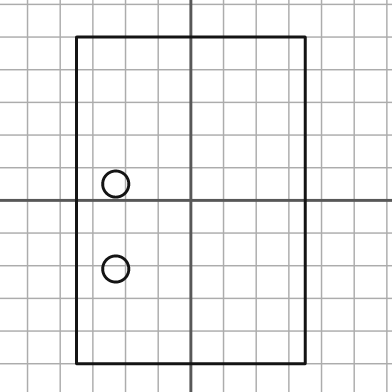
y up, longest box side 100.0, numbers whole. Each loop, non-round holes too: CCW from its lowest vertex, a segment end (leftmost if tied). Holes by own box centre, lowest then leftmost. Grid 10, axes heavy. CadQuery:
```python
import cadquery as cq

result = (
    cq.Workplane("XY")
    .moveTo(-35.0, -50.0)
    .lineTo(35.0, -50.0)
    .lineTo(35.0, 50.0)
    .lineTo(-35.0, 50.0)
    .close()
    .moveTo(-23.0, -21.0)
    .circle(4.0)
    .moveTo(-23.0, 5.0)
    .circle(4.0)
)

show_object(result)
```